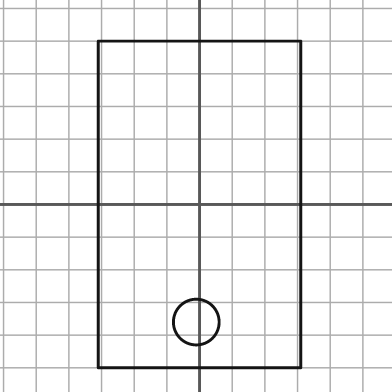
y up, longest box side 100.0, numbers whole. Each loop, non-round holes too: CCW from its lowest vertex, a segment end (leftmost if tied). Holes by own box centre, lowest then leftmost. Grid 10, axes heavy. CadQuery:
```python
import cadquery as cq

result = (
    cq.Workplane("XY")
    .moveTo(-31.0, -50.0)
    .lineTo(31.0, -50.0)
    .lineTo(31.0, 50.0)
    .lineTo(-31.0, 50.0)
    .close()
    .moveTo(-1.0, -36.0)
    .circle(7.0)
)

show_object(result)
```